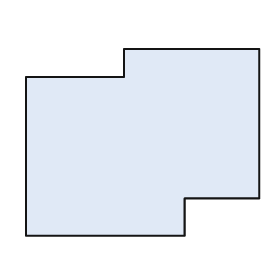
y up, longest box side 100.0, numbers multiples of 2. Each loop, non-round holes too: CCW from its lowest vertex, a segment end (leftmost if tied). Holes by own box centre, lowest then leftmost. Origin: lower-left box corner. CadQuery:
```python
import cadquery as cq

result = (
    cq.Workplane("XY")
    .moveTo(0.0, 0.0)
    .lineTo(68.0, 0.0)
    .lineTo(68.0, 16.0)
    .lineTo(100.0, 16.0)
    .lineTo(100.0, 80.0)
    .lineTo(42.0, 80.0)
    .lineTo(42.0, 68.0)
    .lineTo(0.0, 68.0)
    .close()
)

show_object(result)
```